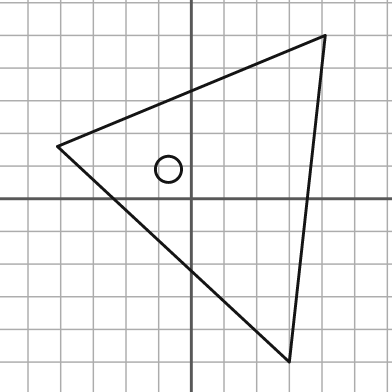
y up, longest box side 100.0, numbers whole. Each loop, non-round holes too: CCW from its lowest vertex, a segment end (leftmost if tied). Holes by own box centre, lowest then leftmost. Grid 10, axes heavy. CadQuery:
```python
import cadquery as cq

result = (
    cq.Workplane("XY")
    .moveTo(30.0, -50.0)
    .lineTo(41.0, 50.0)
    .lineTo(-41.0, 16.0)
    .close()
    .moveTo(-7.0, 9.0)
    .circle(4.0)
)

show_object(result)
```